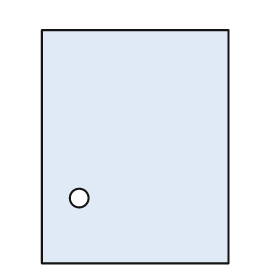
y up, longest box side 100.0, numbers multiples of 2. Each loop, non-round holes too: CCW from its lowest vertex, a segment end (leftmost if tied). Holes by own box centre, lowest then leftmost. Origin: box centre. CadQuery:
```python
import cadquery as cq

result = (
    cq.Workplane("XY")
    .moveTo(-40.0, -50.0)
    .lineTo(40.0, -50.0)
    .lineTo(40.0, 50.0)
    .lineTo(-40.0, 50.0)
    .close()
    .moveTo(-24.0, -22.0)
    .circle(4.0)
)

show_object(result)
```